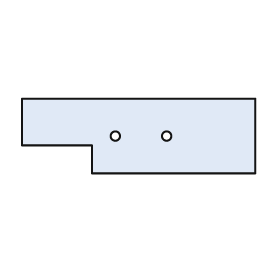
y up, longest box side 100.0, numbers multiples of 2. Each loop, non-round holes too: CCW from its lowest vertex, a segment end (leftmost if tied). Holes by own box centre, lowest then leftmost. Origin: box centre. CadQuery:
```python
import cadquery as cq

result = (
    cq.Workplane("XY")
    .moveTo(-20.0, -16.0)
    .lineTo(50.0, -16.0)
    .lineTo(50.0, 16.0)
    .lineTo(-50.0, 16.0)
    .lineTo(-50.0, -4.0)
    .lineTo(-20.0, -4.0)
    .close()
    .moveTo(-10.0, 0.0)
    .circle(2.0)
    .moveTo(12.0, 0.0)
    .circle(2.0)
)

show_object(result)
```